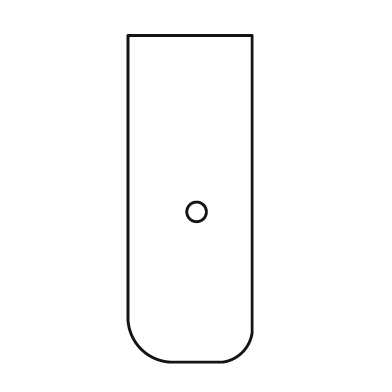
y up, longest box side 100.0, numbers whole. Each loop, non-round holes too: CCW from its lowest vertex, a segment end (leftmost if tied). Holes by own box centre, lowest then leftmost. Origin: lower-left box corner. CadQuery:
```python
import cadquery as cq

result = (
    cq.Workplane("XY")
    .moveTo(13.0, 0.0)
    .lineTo(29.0, 0.0)
    .threePointArc((35.0, 3.0), (38.0, 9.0))
    .lineTo(38.0, 100.0)
    .lineTo(0.0, 100.0)
    .lineTo(0.0, 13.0)
    .threePointArc((4.0, 4.0), (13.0, 0.0))
    .close()
    .moveTo(21.0, 46.0)
    .circle(3.0)
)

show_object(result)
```